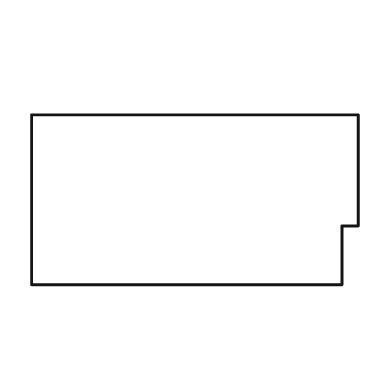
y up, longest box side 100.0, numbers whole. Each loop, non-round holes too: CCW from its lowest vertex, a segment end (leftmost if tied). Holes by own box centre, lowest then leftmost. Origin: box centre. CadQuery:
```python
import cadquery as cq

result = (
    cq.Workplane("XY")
    .moveTo(-50.0, -26.0)
    .lineTo(45.0, -26.0)
    .lineTo(45.0, -8.0)
    .lineTo(50.0, -8.0)
    .lineTo(50.0, 26.0)
    .lineTo(-50.0, 26.0)
    .close()
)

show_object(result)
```